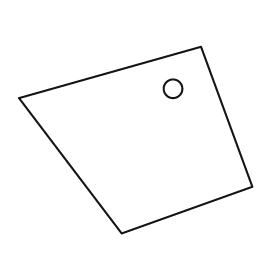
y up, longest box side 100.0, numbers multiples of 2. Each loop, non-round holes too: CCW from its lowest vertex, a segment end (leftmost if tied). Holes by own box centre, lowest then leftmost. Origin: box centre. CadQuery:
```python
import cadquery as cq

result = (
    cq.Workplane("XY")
    .moveTo(-6.0, -40.0)
    .lineTo(50.0, -20.0)
    .lineTo(28.0, 40.0)
    .lineTo(-50.0, 18.0)
    .close()
    .moveTo(16.0, 22.0)
    .circle(4.0)
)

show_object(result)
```